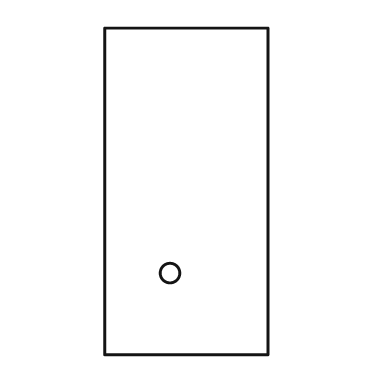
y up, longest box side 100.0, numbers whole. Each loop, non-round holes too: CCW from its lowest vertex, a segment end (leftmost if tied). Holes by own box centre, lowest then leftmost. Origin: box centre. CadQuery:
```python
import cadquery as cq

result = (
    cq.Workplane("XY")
    .moveTo(-25.0, -50.0)
    .lineTo(25.0, -50.0)
    .lineTo(25.0, 50.0)
    .lineTo(-25.0, 50.0)
    .close()
    .moveTo(-5.0, -25.0)
    .circle(3.0)
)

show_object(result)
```